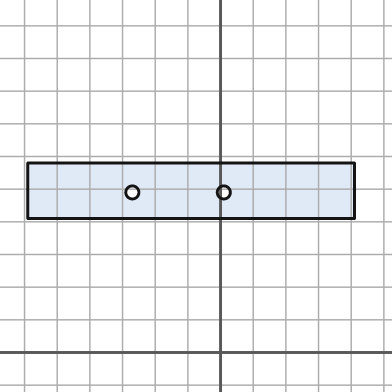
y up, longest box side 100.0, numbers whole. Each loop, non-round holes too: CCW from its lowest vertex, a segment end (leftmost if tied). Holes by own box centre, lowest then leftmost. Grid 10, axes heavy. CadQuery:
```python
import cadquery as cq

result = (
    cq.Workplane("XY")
    .moveTo(-59.0, 41.0)
    .lineTo(41.0, 41.0)
    .lineTo(41.0, 58.0)
    .lineTo(-59.0, 58.0)
    .close()
    .moveTo(-27.0, 49.0)
    .circle(2.0)
    .moveTo(1.0, 49.0)
    .circle(2.0)
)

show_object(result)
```